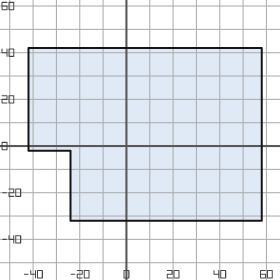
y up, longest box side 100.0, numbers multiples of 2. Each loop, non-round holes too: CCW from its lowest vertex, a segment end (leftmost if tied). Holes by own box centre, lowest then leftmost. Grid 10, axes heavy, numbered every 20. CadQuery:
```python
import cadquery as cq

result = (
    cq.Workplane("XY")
    .moveTo(-24.0, -32.0)
    .lineTo(58.0, -32.0)
    .lineTo(58.0, 42.0)
    .lineTo(-42.0, 42.0)
    .lineTo(-42.0, -2.0)
    .lineTo(-24.0, -2.0)
    .close()
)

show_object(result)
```